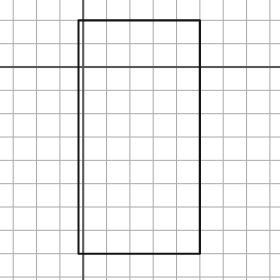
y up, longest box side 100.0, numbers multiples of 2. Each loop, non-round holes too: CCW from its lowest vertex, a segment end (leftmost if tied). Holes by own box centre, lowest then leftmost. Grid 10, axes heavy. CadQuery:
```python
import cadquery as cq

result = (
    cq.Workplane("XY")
    .moveTo(-2.0, -80.0)
    .lineTo(50.0, -80.0)
    .lineTo(50.0, 20.0)
    .lineTo(-2.0, 20.0)
    .close()
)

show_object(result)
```